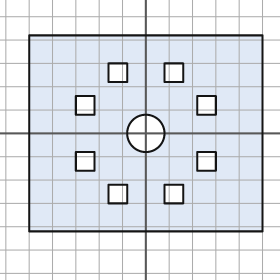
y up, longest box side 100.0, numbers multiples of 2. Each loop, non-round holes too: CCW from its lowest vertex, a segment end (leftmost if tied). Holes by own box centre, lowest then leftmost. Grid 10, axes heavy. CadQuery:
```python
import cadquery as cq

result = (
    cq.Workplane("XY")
    .moveTo(-50.0, -42.0)
    .lineTo(50.0, -42.0)
    .lineTo(50.0, 42.0)
    .lineTo(-50.0, 42.0)
    .close()
    .moveTo(-16.0, -30.0)
    .lineTo(-8.0, -30.0)
    .lineTo(-8.0, -22.0)
    .lineTo(-16.0, -22.0)
    .close()
    .moveTo(8.0, -30.0)
    .lineTo(16.0, -30.0)
    .lineTo(16.0, -22.0)
    .lineTo(8.0, -22.0)
    .close()
    .moveTo(-30.0, -16.0)
    .lineTo(-22.0, -16.0)
    .lineTo(-22.0, -8.0)
    .lineTo(-30.0, -8.0)
    .close()
    .moveTo(22.0, -16.0)
    .lineTo(30.0, -16.0)
    .lineTo(30.0, -8.0)
    .lineTo(22.0, -8.0)
    .close()
    .moveTo(0.0, 0.0)
    .circle(8.0)
    .moveTo(-30.0, 8.0)
    .lineTo(-22.0, 8.0)
    .lineTo(-22.0, 16.0)
    .lineTo(-30.0, 16.0)
    .close()
    .moveTo(22.0, 8.0)
    .lineTo(30.0, 8.0)
    .lineTo(30.0, 16.0)
    .lineTo(22.0, 16.0)
    .close()
    .moveTo(-16.0, 22.0)
    .lineTo(-8.0, 22.0)
    .lineTo(-8.0, 30.0)
    .lineTo(-16.0, 30.0)
    .close()
    .moveTo(8.0, 22.0)
    .lineTo(16.0, 22.0)
    .lineTo(16.0, 30.0)
    .lineTo(8.0, 30.0)
    .close()
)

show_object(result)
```